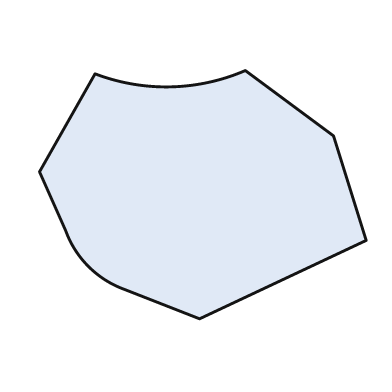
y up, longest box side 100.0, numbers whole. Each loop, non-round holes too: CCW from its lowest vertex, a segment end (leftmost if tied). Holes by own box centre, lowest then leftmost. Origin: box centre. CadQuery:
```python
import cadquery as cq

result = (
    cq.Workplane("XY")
    .moveTo(-1.0, -38.0)
    .lineTo(50.0, -14.0)
    .lineTo(40.0, 18.0)
    .lineTo(13.0, 38.0)
    .threePointArc((-10.0, 33.0), (-33.0, 37.0))
    .lineTo(-50.0, 7.0)
    .lineTo(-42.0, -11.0)
    .threePointArc((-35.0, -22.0), (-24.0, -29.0))
    .close()
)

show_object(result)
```